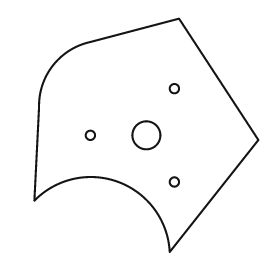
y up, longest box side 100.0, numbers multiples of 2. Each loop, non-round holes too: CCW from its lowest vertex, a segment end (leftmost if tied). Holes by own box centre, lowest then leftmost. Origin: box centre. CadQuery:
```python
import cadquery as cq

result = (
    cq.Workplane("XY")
    .moveTo(10.0, -50.0)
    .lineTo(48.0, -2.0)
    .lineTo(14.0, 50.0)
    .lineTo(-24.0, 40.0)
    .threePointArc((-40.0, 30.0), (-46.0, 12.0))
    .lineTo(-48.0, -28.0)
    .threePointArc((-12.0, -20.0), (10.0, -50.0))
    .close()
    .moveTo(12.0, -20.0)
    .circle(2.0)
    .moveTo(-24.0, 0.0)
    .circle(2.0)
    .moveTo(0.0, 0.0)
    .circle(6.0)
    .moveTo(12.0, 20.0)
    .circle(2.0)
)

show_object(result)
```